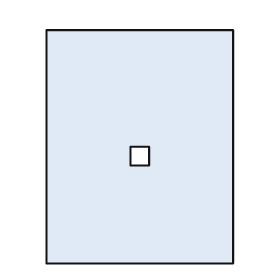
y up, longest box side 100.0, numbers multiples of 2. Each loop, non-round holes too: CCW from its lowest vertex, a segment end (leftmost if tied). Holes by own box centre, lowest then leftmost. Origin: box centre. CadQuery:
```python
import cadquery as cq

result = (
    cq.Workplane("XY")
    .moveTo(-40.0, -50.0)
    .lineTo(40.0, -50.0)
    .lineTo(40.0, 50.0)
    .lineTo(-40.0, 50.0)
    .close()
    .moveTo(-4.0, -8.0)
    .lineTo(4.0, -8.0)
    .lineTo(4.0, 0.0)
    .lineTo(-4.0, 0.0)
    .close()
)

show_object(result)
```